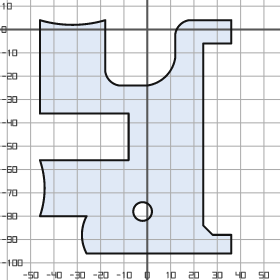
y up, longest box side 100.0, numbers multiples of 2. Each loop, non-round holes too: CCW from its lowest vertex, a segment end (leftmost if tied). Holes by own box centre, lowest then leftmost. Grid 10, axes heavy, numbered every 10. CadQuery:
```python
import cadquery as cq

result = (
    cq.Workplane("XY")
    .moveTo(-26.0, -96.0)
    .lineTo(36.0, -96.0)
    .lineTo(36.0, -88.0)
    .lineTo(28.0, -88.0)
    .lineTo(24.0, -84.0)
    .lineTo(24.0, -6.0)
    .lineTo(36.0, -6.0)
    .lineTo(36.0, 4.0)
    .lineTo(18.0, 4.0)
    .threePointArc((14.0, 2.0), (12.0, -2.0))
    .lineTo(12.0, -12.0)
    .threePointArc((8.0, -20.0), (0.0, -24.0))
    .lineTo(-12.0, -24.0)
    .threePointArc((-16.0, -22.0), (-18.0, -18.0))
    .lineTo(-18.0, 4.0)
    .threePointArc((-32.0, 2.0), (-46.0, 4.0))
    .lineTo(-46.0, -36.0)
    .lineTo(-8.0, -36.0)
    .lineTo(-8.0, -56.0)
    .lineTo(-46.0, -56.0)
    .threePointArc((-44.0, -68.0), (-46.0, -80.0))
    .lineTo(-26.0, -80.0)
    .threePointArc((-28.0, -88.0), (-26.0, -96.0))
    .close()
    .moveTo(-2.0, -78.0)
    .circle(4.0)
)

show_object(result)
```